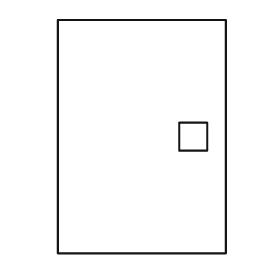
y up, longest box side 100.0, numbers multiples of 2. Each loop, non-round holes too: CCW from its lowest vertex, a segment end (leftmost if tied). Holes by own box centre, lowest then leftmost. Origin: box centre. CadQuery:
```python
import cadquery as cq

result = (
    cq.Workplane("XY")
    .moveTo(-36.0, -50.0)
    .lineTo(36.0, -50.0)
    .lineTo(36.0, 50.0)
    .lineTo(-36.0, 50.0)
    .close()
    .moveTo(16.0, -6.0)
    .lineTo(28.0, -6.0)
    .lineTo(28.0, 6.0)
    .lineTo(16.0, 6.0)
    .close()
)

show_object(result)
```